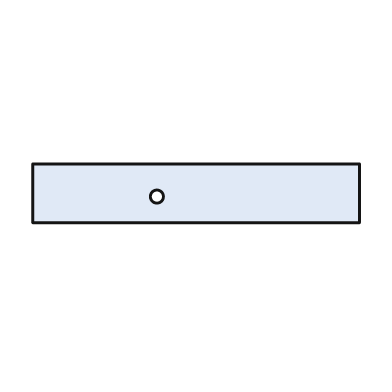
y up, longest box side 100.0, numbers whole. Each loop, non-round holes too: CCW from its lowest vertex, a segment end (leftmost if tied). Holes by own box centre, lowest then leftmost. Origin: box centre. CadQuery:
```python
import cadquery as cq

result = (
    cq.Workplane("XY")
    .moveTo(-50.0, -9.0)
    .lineTo(50.0, -9.0)
    .lineTo(50.0, 9.0)
    .lineTo(-50.0, 9.0)
    .close()
    .moveTo(-12.0, -1.0)
    .circle(2.0)
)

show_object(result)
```